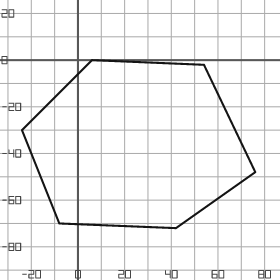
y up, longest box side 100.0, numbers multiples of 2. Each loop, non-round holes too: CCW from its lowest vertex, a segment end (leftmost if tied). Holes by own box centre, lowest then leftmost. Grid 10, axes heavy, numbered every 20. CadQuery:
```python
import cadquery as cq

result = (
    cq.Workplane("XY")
    .moveTo(42.0, -72.0)
    .lineTo(76.0, -48.0)
    .lineTo(54.0, -2.0)
    .lineTo(6.0, 0.0)
    .lineTo(-24.0, -30.0)
    .lineTo(-8.0, -70.0)
    .close()
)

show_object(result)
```